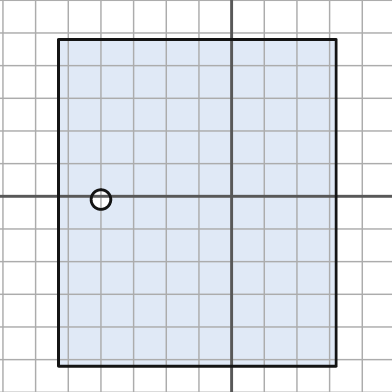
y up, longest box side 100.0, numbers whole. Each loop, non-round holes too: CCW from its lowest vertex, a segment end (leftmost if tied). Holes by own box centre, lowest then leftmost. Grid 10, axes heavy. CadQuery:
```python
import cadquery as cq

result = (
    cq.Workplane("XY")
    .moveTo(-53.0, -52.0)
    .lineTo(32.0, -52.0)
    .lineTo(32.0, 48.0)
    .lineTo(-53.0, 48.0)
    .close()
    .moveTo(-40.0, -1.0)
    .circle(3.0)
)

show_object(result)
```